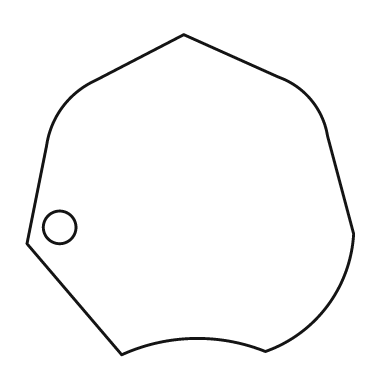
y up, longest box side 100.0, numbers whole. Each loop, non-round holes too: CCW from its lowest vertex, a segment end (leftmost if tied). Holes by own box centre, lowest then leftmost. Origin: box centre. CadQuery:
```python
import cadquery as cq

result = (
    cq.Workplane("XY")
    .moveTo(-21.0, -49.0)
    .threePointArc((1.0, -44.0), (23.0, -48.0))
    .threePointArc((42.0, -34.0), (50.0, -12.0))
    .lineTo(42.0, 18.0)
    .threePointArc((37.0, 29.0), (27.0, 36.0))
    .lineTo(-2.0, 49.0)
    .lineTo(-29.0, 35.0)
    .threePointArc((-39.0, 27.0), (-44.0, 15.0))
    .lineTo(-50.0, -15.0)
    .close()
    .moveTo(-40.0, -10.0)
    .circle(5.0)
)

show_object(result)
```